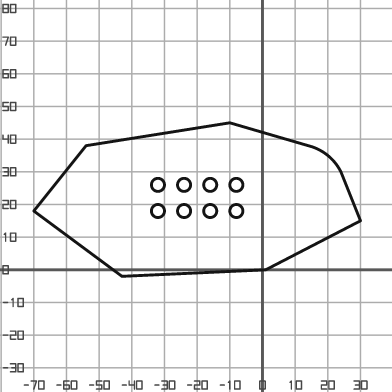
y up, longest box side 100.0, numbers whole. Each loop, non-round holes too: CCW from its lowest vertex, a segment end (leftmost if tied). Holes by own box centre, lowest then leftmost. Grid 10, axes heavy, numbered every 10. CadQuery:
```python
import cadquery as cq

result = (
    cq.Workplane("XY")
    .moveTo(-43.0, -2.0)
    .lineTo(1.0, 0.0)
    .lineTo(30.0, 15.0)
    .lineTo(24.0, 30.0)
    .threePointArc((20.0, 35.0), (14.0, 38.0))
    .lineTo(-10.0, 45.0)
    .lineTo(-54.0, 38.0)
    .lineTo(-70.0, 18.0)
    .close()
    .moveTo(-32.0, 18.0)
    .circle(2.0)
    .moveTo(-24.0, 18.0)
    .circle(2.0)
    .moveTo(-16.0, 18.0)
    .circle(2.0)
    .moveTo(-8.0, 18.0)
    .circle(2.0)
    .moveTo(-32.0, 26.0)
    .circle(2.0)
    .moveTo(-24.0, 26.0)
    .circle(2.0)
    .moveTo(-16.0, 26.0)
    .circle(2.0)
    .moveTo(-8.0, 26.0)
    .circle(2.0)
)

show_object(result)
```